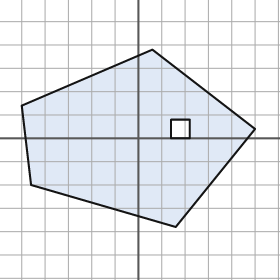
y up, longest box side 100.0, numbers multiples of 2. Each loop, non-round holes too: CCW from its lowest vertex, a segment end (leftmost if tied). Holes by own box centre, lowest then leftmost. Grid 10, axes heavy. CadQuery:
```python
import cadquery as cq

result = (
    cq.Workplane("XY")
    .moveTo(16.0, -38.0)
    .lineTo(50.0, 4.0)
    .lineTo(6.0, 38.0)
    .lineTo(-50.0, 14.0)
    .lineTo(-46.0, -20.0)
    .close()
    .moveTo(14.0, 0.0)
    .lineTo(22.0, 0.0)
    .lineTo(22.0, 8.0)
    .lineTo(14.0, 8.0)
    .close()
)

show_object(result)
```